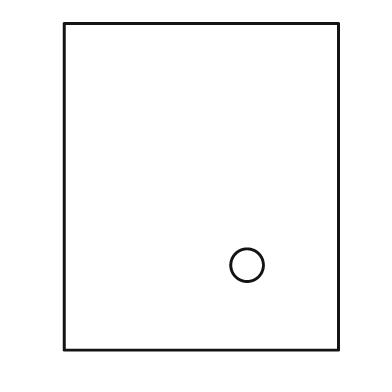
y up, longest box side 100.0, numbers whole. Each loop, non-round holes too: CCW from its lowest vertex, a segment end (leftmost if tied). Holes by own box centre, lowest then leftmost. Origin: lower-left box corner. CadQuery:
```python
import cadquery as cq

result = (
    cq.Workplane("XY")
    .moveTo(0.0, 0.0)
    .lineTo(84.0, 0.0)
    .lineTo(84.0, 100.0)
    .lineTo(0.0, 100.0)
    .close()
    .moveTo(56.0, 26.0)
    .circle(5.0)
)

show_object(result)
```